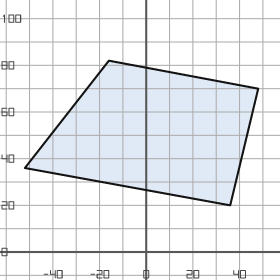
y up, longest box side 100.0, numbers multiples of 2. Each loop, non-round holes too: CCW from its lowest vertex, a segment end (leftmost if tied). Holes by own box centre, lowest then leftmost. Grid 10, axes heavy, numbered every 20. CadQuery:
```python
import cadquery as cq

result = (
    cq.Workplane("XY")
    .moveTo(36.0, 20.0)
    .lineTo(48.0, 70.0)
    .lineTo(-16.0, 82.0)
    .lineTo(-52.0, 36.0)
    .close()
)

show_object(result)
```